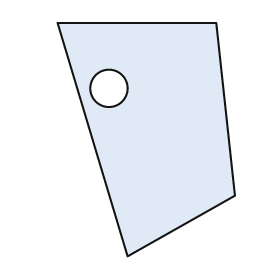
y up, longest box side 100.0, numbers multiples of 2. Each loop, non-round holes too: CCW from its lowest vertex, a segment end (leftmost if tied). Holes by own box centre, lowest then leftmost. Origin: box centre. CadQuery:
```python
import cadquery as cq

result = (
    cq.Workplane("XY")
    .moveTo(-8.0, -50.0)
    .lineTo(38.0, -24.0)
    .lineTo(30.0, 50.0)
    .lineTo(-38.0, 50.0)
    .close()
    .moveTo(-16.0, 22.0)
    .circle(8.0)
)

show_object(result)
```